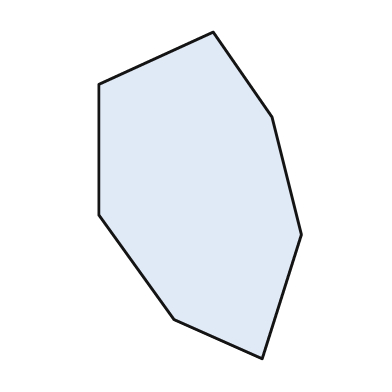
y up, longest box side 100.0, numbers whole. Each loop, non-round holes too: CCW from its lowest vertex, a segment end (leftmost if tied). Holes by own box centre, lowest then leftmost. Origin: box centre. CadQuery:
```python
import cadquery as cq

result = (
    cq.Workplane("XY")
    .moveTo(19.0, -50.0)
    .lineTo(31.0, -12.0)
    .lineTo(22.0, 24.0)
    .lineTo(4.0, 50.0)
    .lineTo(-31.0, 34.0)
    .lineTo(-31.0, -6.0)
    .lineTo(-8.0, -38.0)
    .close()
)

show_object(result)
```